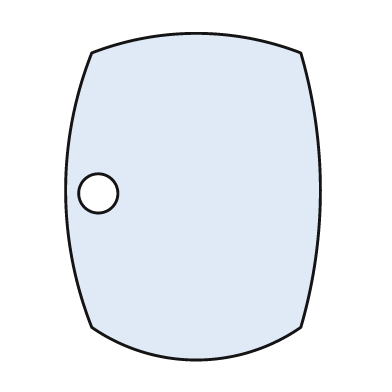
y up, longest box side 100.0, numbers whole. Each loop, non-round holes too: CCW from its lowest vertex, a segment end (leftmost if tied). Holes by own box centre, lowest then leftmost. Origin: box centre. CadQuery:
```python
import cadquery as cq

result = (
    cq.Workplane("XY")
    .moveTo(-31.0, -40.0)
    .threePointArc((1.0, -50.0), (33.0, -40.0))
    .threePointArc((39.0, 2.0), (33.0, 44.0))
    .threePointArc((1.0, 50.0), (-31.0, 44.0))
    .threePointArc((-39.0, 2.0), (-31.0, -40.0))
    .close()
    .moveTo(-29.0, 1.0)
    .circle(6.0)
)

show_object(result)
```